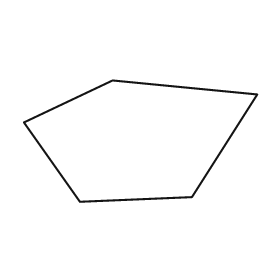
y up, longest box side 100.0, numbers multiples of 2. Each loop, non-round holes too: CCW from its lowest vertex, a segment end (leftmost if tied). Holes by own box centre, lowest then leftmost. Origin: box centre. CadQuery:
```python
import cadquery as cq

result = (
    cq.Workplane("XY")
    .moveTo(-26.0, -26.0)
    .lineTo(22.0, -24.0)
    .lineTo(50.0, 20.0)
    .lineTo(-12.0, 26.0)
    .lineTo(-50.0, 8.0)
    .close()
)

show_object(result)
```